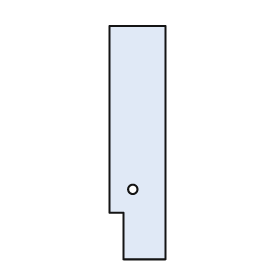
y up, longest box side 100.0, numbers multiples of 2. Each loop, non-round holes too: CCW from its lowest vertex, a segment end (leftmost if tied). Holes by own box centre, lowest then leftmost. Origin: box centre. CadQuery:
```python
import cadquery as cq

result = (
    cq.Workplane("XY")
    .moveTo(-6.0, -50.0)
    .lineTo(12.0, -50.0)
    .lineTo(12.0, 50.0)
    .lineTo(-12.0, 50.0)
    .lineTo(-12.0, -30.0)
    .lineTo(-6.0, -30.0)
    .close()
    .moveTo(-2.0, -20.0)
    .circle(2.0)
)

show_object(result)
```